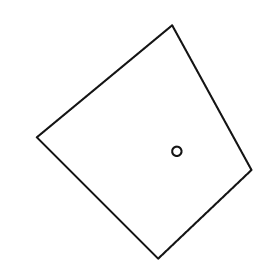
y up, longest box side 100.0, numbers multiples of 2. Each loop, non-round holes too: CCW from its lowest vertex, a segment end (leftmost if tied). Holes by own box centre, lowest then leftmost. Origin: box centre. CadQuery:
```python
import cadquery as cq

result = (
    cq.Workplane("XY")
    .moveTo(6.0, -50.0)
    .lineTo(46.0, -12.0)
    .lineTo(12.0, 50.0)
    .lineTo(-46.0, 2.0)
    .close()
    .moveTo(14.0, -4.0)
    .circle(2.0)
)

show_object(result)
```